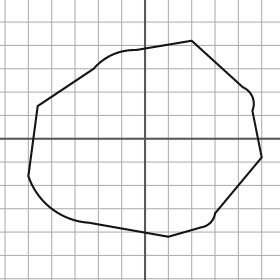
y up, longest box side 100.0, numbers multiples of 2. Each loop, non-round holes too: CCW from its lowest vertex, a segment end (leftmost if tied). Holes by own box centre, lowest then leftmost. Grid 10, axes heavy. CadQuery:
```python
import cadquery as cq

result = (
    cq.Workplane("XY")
    .moveTo(10.0, -42.0)
    .lineTo(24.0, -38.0)
    .threePointArc((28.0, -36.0), (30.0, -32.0))
    .lineTo(50.0, -8.0)
    .lineTo(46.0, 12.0)
    .threePointArc((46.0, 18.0), (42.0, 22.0))
    .lineTo(20.0, 42.0)
    .lineTo(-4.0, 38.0)
    .threePointArc((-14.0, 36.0), (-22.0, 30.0))
    .lineTo(-46.0, 14.0)
    .lineTo(-50.0, -16.0)
    .threePointArc((-40.0, -30.0), (-24.0, -36.0))
    .close()
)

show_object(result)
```